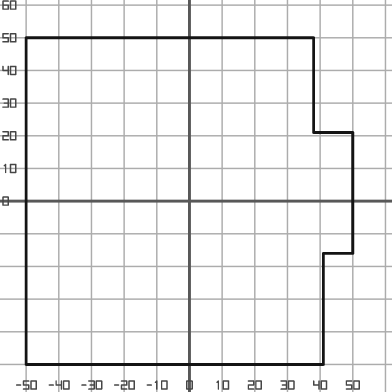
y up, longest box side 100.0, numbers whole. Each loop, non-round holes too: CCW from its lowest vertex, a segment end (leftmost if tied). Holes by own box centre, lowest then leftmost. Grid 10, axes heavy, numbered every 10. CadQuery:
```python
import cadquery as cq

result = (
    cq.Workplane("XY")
    .moveTo(-50.0, -50.0)
    .lineTo(41.0, -50.0)
    .lineTo(41.0, -16.0)
    .lineTo(50.0, -16.0)
    .lineTo(50.0, 21.0)
    .lineTo(38.0, 21.0)
    .lineTo(38.0, 50.0)
    .lineTo(-50.0, 50.0)
    .close()
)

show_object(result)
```